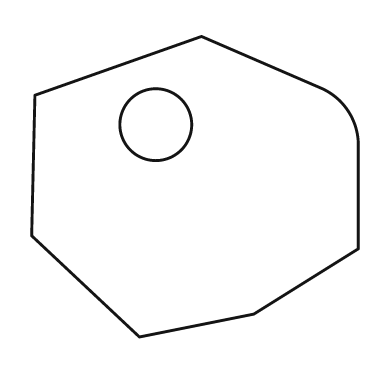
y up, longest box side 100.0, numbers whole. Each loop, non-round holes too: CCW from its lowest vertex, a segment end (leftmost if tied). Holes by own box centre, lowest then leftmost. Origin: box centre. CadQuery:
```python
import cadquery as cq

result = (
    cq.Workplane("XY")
    .moveTo(-17.0, -46.0)
    .lineTo(18.0, -39.0)
    .lineTo(50.0, -19.0)
    .lineTo(50.0, 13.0)
    .threePointArc((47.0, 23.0), (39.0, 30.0))
    .lineTo(2.0, 46.0)
    .lineTo(-49.0, 28.0)
    .lineTo(-50.0, -15.0)
    .close()
    .moveTo(-12.0, 19.0)
    .circle(11.0)
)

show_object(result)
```